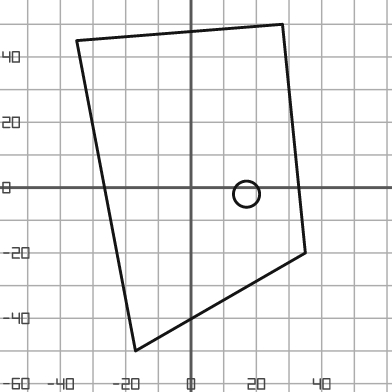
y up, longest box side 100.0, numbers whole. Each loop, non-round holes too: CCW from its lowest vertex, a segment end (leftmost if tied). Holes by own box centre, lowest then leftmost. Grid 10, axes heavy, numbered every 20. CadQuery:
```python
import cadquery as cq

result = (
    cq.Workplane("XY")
    .moveTo(-17.0, -50.0)
    .lineTo(35.0, -20.0)
    .lineTo(28.0, 50.0)
    .lineTo(-35.0, 45.0)
    .close()
    .moveTo(17.0, -2.0)
    .circle(4.0)
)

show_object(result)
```